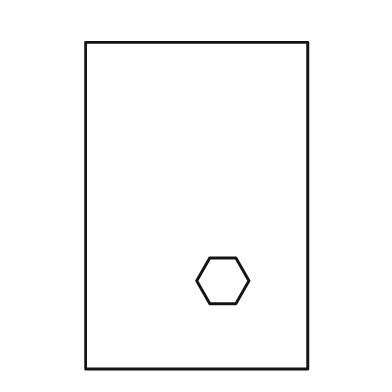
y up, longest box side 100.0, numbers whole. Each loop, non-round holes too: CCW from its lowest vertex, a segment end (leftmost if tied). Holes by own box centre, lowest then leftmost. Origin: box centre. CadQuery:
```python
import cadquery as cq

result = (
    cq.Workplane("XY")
    .moveTo(-34.0, -50.0)
    .lineTo(34.0, -50.0)
    .lineTo(34.0, 50.0)
    .lineTo(-34.0, 50.0)
    .close()
    .moveTo(4.0, -30.0)
    .lineTo(12.0, -30.0)
    .lineTo(16.0, -23.0)
    .lineTo(12.0, -16.0)
    .lineTo(4.0, -16.0)
    .lineTo(0.0, -23.0)
    .close()
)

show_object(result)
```